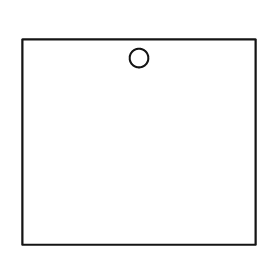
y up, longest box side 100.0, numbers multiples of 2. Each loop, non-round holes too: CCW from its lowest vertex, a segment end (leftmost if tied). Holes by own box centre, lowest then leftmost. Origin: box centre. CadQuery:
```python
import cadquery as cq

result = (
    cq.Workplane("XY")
    .moveTo(-50.0, -44.0)
    .lineTo(50.0, -44.0)
    .lineTo(50.0, 44.0)
    .lineTo(-50.0, 44.0)
    .close()
    .moveTo(0.0, 36.0)
    .circle(4.0)
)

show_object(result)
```